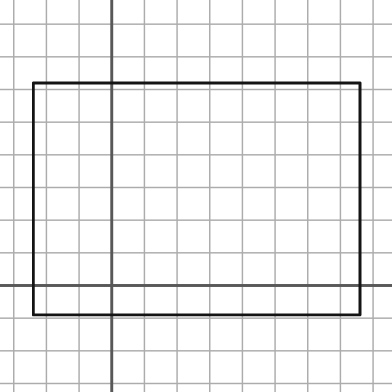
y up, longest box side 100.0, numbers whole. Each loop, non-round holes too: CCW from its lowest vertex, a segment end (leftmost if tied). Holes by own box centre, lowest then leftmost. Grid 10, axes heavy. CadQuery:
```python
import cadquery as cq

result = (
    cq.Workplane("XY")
    .moveTo(-24.0, -9.0)
    .lineTo(76.0, -9.0)
    .lineTo(76.0, 62.0)
    .lineTo(-24.0, 62.0)
    .close()
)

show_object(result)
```